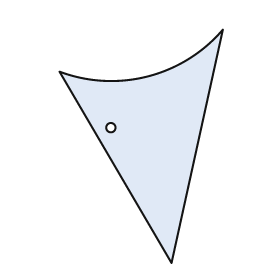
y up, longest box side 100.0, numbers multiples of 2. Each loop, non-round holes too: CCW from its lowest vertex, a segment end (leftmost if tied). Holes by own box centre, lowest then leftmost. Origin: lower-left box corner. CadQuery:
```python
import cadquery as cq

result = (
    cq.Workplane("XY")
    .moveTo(48.0, 0.0)
    .lineTo(70.0, 100.0)
    .threePointArc((38.0, 80.0), (0.0, 82.0))
    .close()
    .moveTo(22.0, 58.0)
    .circle(2.0)
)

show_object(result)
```